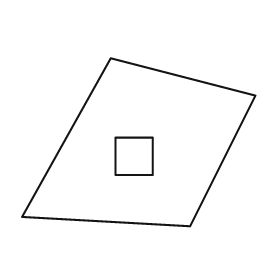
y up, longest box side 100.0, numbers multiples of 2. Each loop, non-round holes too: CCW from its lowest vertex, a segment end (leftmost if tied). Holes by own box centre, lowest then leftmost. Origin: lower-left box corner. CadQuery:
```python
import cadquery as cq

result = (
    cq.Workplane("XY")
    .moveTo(72.0, 0.0)
    .lineTo(100.0, 56.0)
    .lineTo(38.0, 72.0)
    .lineTo(0.0, 4.0)
    .close()
    .moveTo(40.0, 22.0)
    .lineTo(56.0, 22.0)
    .lineTo(56.0, 38.0)
    .lineTo(40.0, 38.0)
    .close()
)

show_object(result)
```